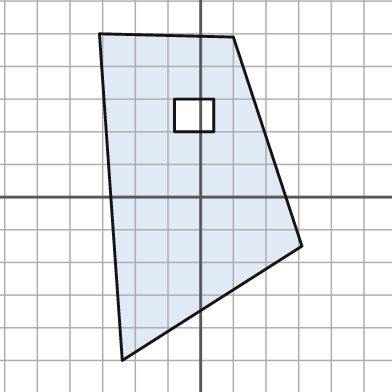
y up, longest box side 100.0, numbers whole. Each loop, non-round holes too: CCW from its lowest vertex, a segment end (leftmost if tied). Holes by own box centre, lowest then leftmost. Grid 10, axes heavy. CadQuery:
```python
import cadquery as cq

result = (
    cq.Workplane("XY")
    .moveTo(-24.0, -50.0)
    .lineTo(31.0, -15.0)
    .lineTo(10.0, 49.0)
    .lineTo(-31.0, 50.0)
    .close()
    .moveTo(-8.0, 20.0)
    .lineTo(4.0, 20.0)
    .lineTo(4.0, 30.0)
    .lineTo(-8.0, 30.0)
    .close()
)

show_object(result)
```